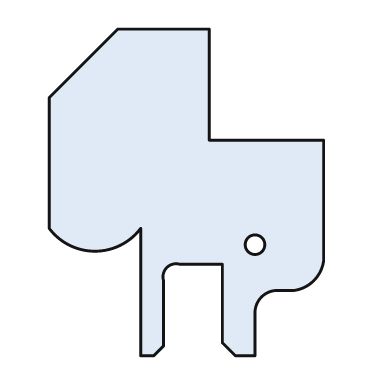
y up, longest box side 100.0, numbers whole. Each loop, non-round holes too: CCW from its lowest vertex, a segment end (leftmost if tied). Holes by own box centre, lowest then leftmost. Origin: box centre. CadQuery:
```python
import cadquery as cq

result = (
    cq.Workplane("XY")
    .moveTo(-14.0, -50.0)
    .lineTo(-10.0, -50.0)
    .lineTo(-7.0, -47.0)
    .lineTo(-7.0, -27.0)
    .threePointArc((-6.0, -23.0), (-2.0, -22.0))
    .lineTo(11.0, -22.0)
    .lineTo(11.0, -46.0)
    .lineTo(15.0, -50.0)
    .lineTo(21.0, -50.0)
    .lineTo(21.0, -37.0)
    .threePointArc((23.0, -32.0), (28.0, -30.0))
    .lineTo(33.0, -30.0)
    .threePointArc((39.0, -27.0), (42.0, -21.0))
    .lineTo(42.0, 16.0)
    .lineTo(7.0, 16.0)
    .lineTo(7.0, 50.0)
    .lineTo(-21.0, 50.0)
    .lineTo(-42.0, 29.0)
    .lineTo(-42.0, -11.0)
    .threePointArc((-28.0, -18.0), (-14.0, -11.0))
    .close()
    .moveTo(21.0, -16.0)
    .circle(3.0)
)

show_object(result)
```